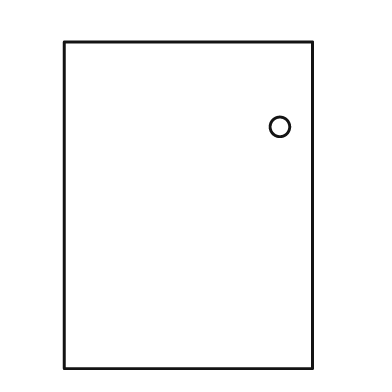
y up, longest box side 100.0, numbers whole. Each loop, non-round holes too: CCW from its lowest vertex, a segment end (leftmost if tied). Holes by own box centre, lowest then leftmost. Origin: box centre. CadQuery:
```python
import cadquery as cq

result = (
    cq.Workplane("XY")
    .moveTo(-38.0, -50.0)
    .lineTo(38.0, -50.0)
    .lineTo(38.0, 50.0)
    .lineTo(-38.0, 50.0)
    .close()
    .moveTo(28.0, 24.0)
    .circle(3.0)
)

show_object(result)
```